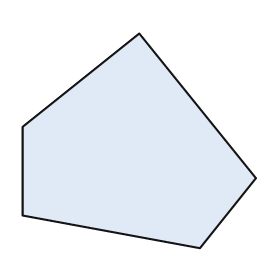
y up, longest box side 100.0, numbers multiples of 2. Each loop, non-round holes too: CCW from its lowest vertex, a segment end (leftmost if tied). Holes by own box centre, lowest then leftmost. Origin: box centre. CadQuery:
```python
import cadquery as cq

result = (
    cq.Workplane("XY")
    .moveTo(26.0, -46.0)
    .lineTo(50.0, -16.0)
    .lineTo(0.0, 46.0)
    .lineTo(-50.0, 6.0)
    .lineTo(-50.0, -32.0)
    .close()
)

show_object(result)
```